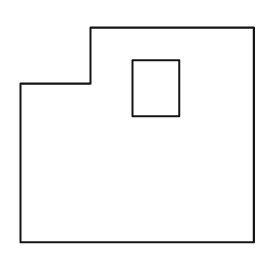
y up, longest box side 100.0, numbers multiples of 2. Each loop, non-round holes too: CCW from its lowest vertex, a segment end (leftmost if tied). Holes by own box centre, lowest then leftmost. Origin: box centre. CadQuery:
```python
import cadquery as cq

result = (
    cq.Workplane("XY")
    .moveTo(-50.0, -46.0)
    .lineTo(50.0, -46.0)
    .lineTo(50.0, 46.0)
    .lineTo(-20.0, 46.0)
    .lineTo(-20.0, 22.0)
    .lineTo(-50.0, 22.0)
    .close()
    .moveTo(-2.0, 8.0)
    .lineTo(18.0, 8.0)
    .lineTo(18.0, 32.0)
    .lineTo(-2.0, 32.0)
    .close()
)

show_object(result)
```